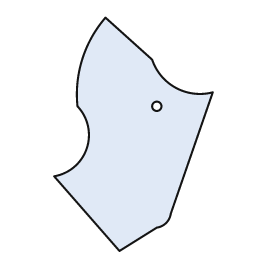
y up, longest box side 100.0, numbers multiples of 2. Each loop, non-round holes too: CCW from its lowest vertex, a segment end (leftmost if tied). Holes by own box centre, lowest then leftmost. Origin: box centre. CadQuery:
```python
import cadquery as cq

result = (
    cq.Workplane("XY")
    .moveTo(-6.0, -50.0)
    .lineTo(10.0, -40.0)
    .threePointArc((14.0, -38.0), (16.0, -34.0))
    .lineTo(34.0, 18.0)
    .threePointArc((18.0, 20.0), (8.0, 32.0))
    .lineTo(-12.0, 50.0)
    .threePointArc((-22.0, 32.0), (-24.0, 12.0))
    .threePointArc((-20.0, -6.0), (-34.0, -18.0))
    .close()
    .moveTo(10.0, 12.0)
    .circle(2.0)
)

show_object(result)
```